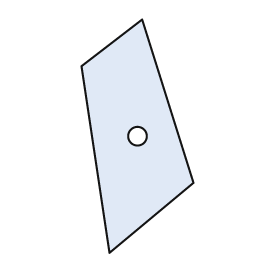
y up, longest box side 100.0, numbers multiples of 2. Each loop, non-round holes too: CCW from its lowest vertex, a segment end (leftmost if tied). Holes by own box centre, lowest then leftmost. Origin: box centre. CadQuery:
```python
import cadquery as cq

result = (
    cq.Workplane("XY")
    .moveTo(-12.0, -50.0)
    .lineTo(24.0, -20.0)
    .lineTo(2.0, 50.0)
    .lineTo(-24.0, 30.0)
    .close()
    .moveTo(0.0, 0.0)
    .circle(4.0)
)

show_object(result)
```